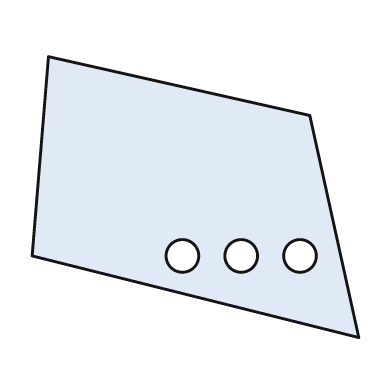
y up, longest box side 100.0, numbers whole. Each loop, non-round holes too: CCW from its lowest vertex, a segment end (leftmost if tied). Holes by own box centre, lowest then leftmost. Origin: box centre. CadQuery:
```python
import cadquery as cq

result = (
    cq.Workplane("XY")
    .moveTo(50.0, -43.0)
    .lineTo(35.0, 25.0)
    .lineTo(-45.0, 43.0)
    .lineTo(-50.0, -18.0)
    .close()
    .moveTo(-4.0, -18.0)
    .circle(5.0)
    .moveTo(14.0, -18.0)
    .circle(5.0)
    .moveTo(32.0, -18.0)
    .circle(5.0)
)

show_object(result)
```